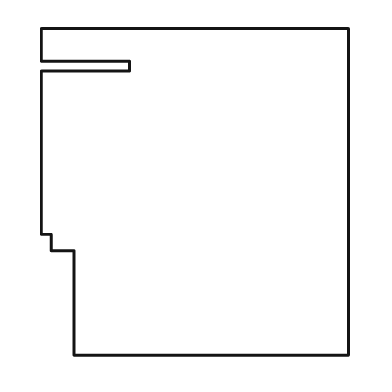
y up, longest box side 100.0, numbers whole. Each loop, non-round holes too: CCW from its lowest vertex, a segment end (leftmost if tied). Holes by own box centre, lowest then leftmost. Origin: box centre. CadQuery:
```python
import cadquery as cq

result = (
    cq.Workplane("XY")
    .moveTo(-37.0, -50.0)
    .lineTo(47.0, -50.0)
    .lineTo(47.0, 50.0)
    .lineTo(-47.0, 50.0)
    .lineTo(-47.0, 40.0)
    .lineTo(-20.0, 40.0)
    .lineTo(-20.0, 37.0)
    .lineTo(-47.0, 37.0)
    .lineTo(-47.0, -13.0)
    .lineTo(-44.0, -13.0)
    .lineTo(-44.0, -18.0)
    .lineTo(-37.0, -18.0)
    .close()
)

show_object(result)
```